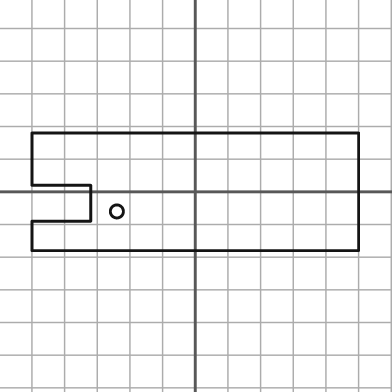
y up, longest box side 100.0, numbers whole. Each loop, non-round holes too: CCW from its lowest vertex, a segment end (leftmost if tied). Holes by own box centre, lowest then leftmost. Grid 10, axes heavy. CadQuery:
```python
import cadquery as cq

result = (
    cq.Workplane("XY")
    .moveTo(-50.0, -18.0)
    .lineTo(50.0, -18.0)
    .lineTo(50.0, 18.0)
    .lineTo(-50.0, 18.0)
    .lineTo(-50.0, 2.0)
    .lineTo(-32.0, 2.0)
    .lineTo(-32.0, -9.0)
    .lineTo(-50.0, -9.0)
    .close()
    .moveTo(-24.0, -6.0)
    .circle(2.0)
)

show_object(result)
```